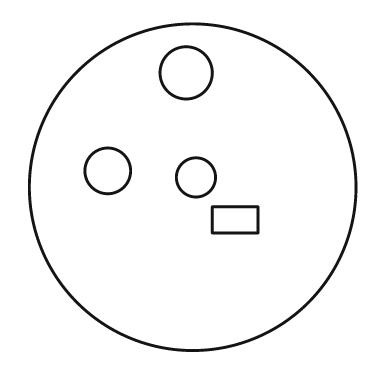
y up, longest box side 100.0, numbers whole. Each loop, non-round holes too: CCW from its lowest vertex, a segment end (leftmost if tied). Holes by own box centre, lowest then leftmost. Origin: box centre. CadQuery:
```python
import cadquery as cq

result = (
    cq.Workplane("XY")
    .moveTo(0.0, 0.0)
    .circle(50.0)
    .moveTo(6.0, -14.0)
    .lineTo(20.0, -14.0)
    .lineTo(20.0, -6.0)
    .lineTo(6.0, -6.0)
    .close()
    .moveTo(1.0, 3.0)
    .circle(6.0)
    .moveTo(-26.0, 5.0)
    .circle(7.0)
    .moveTo(-2.0, 35.0)
    .circle(8.0)
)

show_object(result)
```